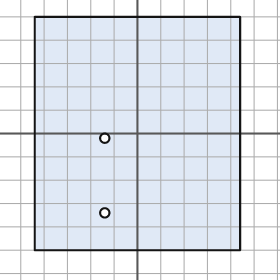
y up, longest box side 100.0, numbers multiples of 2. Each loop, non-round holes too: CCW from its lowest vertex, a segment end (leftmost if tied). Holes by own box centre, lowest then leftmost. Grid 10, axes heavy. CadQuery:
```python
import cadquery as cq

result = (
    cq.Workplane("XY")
    .moveTo(-44.0, -50.0)
    .lineTo(44.0, -50.0)
    .lineTo(44.0, 50.0)
    .lineTo(-44.0, 50.0)
    .close()
    .moveTo(-14.0, -34.0)
    .circle(2.0)
    .moveTo(-14.0, -2.0)
    .circle(2.0)
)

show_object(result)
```